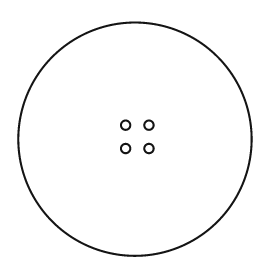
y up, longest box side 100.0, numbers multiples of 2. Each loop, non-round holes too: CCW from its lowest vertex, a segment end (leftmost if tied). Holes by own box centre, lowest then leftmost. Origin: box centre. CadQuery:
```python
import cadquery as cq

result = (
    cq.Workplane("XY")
    .moveTo(0.0, 0.0)
    .circle(50.0)
    .moveTo(-4.0, -4.0)
    .circle(2.0)
    .moveTo(6.0, -4.0)
    .circle(2.0)
    .moveTo(-4.0, 6.0)
    .circle(2.0)
    .moveTo(6.0, 6.0)
    .circle(2.0)
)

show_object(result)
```